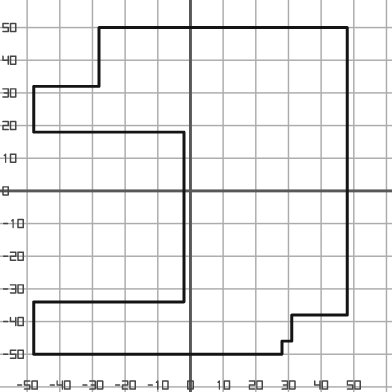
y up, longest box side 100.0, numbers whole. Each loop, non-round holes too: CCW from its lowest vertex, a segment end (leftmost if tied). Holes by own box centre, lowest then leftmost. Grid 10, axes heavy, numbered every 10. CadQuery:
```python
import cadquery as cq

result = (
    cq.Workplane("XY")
    .moveTo(-48.0, -50.0)
    .lineTo(28.0, -50.0)
    .lineTo(28.0, -46.0)
    .lineTo(31.0, -46.0)
    .lineTo(31.0, -38.0)
    .lineTo(48.0, -38.0)
    .lineTo(48.0, 50.0)
    .lineTo(-28.0, 50.0)
    .lineTo(-28.0, 32.0)
    .lineTo(-48.0, 32.0)
    .lineTo(-48.0, 18.0)
    .lineTo(-2.0, 18.0)
    .lineTo(-2.0, -34.0)
    .lineTo(-48.0, -34.0)
    .close()
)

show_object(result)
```